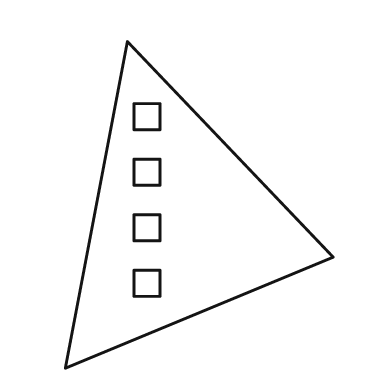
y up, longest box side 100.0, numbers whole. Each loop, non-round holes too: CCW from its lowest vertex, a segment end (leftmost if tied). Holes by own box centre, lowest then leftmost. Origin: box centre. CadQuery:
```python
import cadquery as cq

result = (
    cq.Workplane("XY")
    .moveTo(-41.0, -50.0)
    .lineTo(41.0, -16.0)
    .lineTo(-22.0, 50.0)
    .close()
    .moveTo(-20.0, -28.0)
    .lineTo(-12.0, -28.0)
    .lineTo(-12.0, -20.0)
    .lineTo(-20.0, -20.0)
    .close()
    .moveTo(-20.0, -11.0)
    .lineTo(-12.0, -11.0)
    .lineTo(-12.0, -3.0)
    .lineTo(-20.0, -3.0)
    .close()
    .moveTo(-20.0, 6.0)
    .lineTo(-12.0, 6.0)
    .lineTo(-12.0, 14.0)
    .lineTo(-20.0, 14.0)
    .close()
    .moveTo(-20.0, 23.0)
    .lineTo(-12.0, 23.0)
    .lineTo(-12.0, 31.0)
    .lineTo(-20.0, 31.0)
    .close()
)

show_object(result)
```